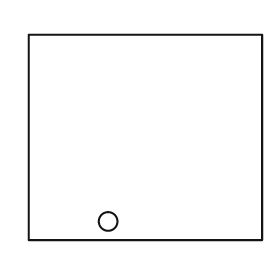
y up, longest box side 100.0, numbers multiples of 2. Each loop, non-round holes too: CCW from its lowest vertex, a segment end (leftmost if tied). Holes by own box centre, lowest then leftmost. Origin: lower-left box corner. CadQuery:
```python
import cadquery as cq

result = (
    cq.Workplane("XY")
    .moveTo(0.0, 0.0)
    .lineTo(100.0, 0.0)
    .lineTo(100.0, 88.0)
    .lineTo(0.0, 88.0)
    .close()
    .moveTo(34.0, 8.0)
    .circle(4.0)
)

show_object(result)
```